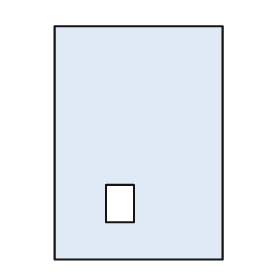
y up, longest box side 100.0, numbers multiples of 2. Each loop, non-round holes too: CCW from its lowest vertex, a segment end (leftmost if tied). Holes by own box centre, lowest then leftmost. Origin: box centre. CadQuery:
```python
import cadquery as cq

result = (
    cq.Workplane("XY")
    .moveTo(-36.0, -50.0)
    .lineTo(36.0, -50.0)
    .lineTo(36.0, 50.0)
    .lineTo(-36.0, 50.0)
    .close()
    .moveTo(-14.0, -34.0)
    .lineTo(-2.0, -34.0)
    .lineTo(-2.0, -18.0)
    .lineTo(-14.0, -18.0)
    .close()
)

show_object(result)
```